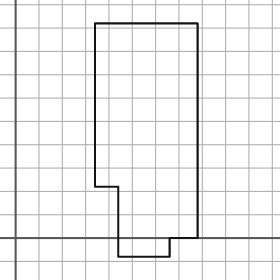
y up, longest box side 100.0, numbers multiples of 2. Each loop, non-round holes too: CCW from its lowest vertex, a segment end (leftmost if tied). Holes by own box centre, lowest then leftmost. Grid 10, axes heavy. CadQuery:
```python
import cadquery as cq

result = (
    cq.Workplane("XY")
    .moveTo(44.0, -8.0)
    .lineTo(66.0, -8.0)
    .lineTo(66.0, 0.0)
    .lineTo(78.0, 0.0)
    .lineTo(78.0, 92.0)
    .lineTo(34.0, 92.0)
    .lineTo(34.0, 22.0)
    .lineTo(44.0, 22.0)
    .close()
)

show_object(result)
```